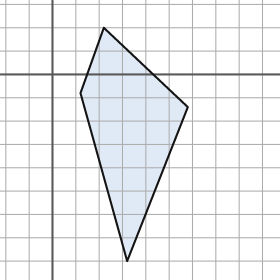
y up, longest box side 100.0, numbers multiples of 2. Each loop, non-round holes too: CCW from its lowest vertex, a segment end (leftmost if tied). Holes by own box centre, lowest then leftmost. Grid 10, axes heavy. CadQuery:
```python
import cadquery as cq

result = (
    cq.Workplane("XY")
    .moveTo(32.0, -80.0)
    .lineTo(58.0, -14.0)
    .lineTo(22.0, 20.0)
    .lineTo(12.0, -8.0)
    .close()
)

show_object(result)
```